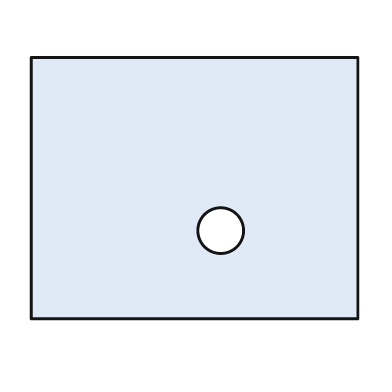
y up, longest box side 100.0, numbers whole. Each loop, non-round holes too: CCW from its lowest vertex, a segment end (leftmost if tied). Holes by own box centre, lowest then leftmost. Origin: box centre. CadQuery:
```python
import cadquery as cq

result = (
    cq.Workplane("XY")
    .moveTo(-50.0, -40.0)
    .lineTo(50.0, -40.0)
    .lineTo(50.0, 40.0)
    .lineTo(-50.0, 40.0)
    .close()
    .moveTo(8.0, -13.0)
    .circle(7.0)
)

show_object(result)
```